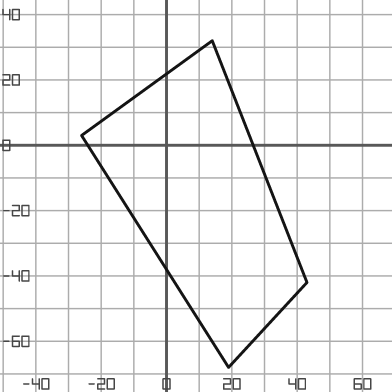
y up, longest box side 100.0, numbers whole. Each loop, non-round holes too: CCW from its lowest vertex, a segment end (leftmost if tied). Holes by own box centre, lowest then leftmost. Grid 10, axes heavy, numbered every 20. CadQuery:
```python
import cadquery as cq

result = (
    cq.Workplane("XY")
    .moveTo(19.0, -68.0)
    .lineTo(43.0, -42.0)
    .lineTo(14.0, 32.0)
    .lineTo(-26.0, 3.0)
    .close()
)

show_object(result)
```